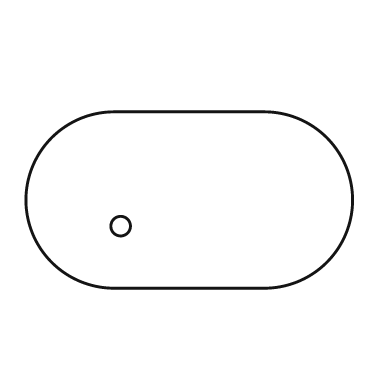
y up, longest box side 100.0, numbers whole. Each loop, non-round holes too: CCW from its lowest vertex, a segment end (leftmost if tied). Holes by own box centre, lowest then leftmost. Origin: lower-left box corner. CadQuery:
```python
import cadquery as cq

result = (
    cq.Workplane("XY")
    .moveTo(27.0, 0.0)
    .lineTo(73.0, 0.0)
    .threePointArc((100.0, 27.0), (73.0, 54.0))
    .lineTo(27.0, 54.0)
    .threePointArc((0.0, 27.0), (27.0, 0.0))
    .close()
    .moveTo(29.0, 19.0)
    .circle(3.0)
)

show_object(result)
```